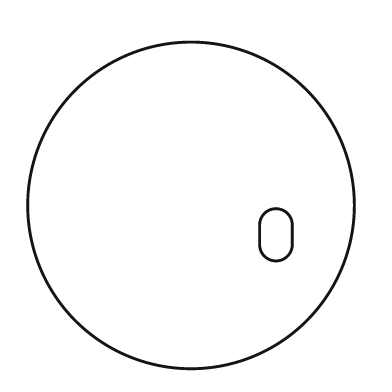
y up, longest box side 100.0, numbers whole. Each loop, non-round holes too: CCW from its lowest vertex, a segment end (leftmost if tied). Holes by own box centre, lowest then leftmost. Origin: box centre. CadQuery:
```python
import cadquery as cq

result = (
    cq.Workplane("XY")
    .moveTo(0.0, 0.0)
    .circle(50.0)
    .moveTo(21.0, -12.0)
    .threePointArc((26.0, -17.0), (31.0, -12.0))
    .lineTo(31.0, -6.0)
    .threePointArc((26.0, -1.0), (21.0, -6.0))
    .close()
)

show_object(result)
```